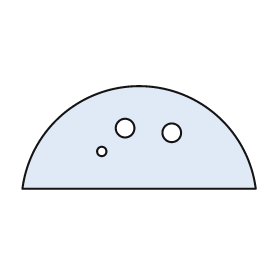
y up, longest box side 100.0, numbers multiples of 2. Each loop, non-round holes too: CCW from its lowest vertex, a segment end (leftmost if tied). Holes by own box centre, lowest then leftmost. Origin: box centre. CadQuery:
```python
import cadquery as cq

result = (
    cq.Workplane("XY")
    .moveTo(-50.0, -22.0)
    .lineTo(50.0, -22.0)
    .threePointArc((0.0, 22.0), (-50.0, -22.0))
    .close()
    .moveTo(-16.0, -6.0)
    .circle(2.0)
    .moveTo(14.0, 2.0)
    .circle(4.0)
    .moveTo(-6.0, 4.0)
    .circle(4.0)
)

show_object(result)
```